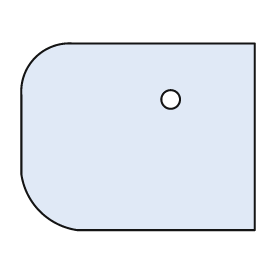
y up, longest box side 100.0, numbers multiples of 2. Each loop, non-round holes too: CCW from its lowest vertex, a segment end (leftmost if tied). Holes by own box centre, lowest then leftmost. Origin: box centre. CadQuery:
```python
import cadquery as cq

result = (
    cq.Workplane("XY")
    .moveTo(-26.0, -40.0)
    .lineTo(50.0, -40.0)
    .lineTo(50.0, 40.0)
    .lineTo(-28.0, 40.0)
    .threePointArc((-44.0, 34.0), (-50.0, 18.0))
    .lineTo(-50.0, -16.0)
    .threePointArc((-42.0, -32.0), (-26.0, -40.0))
    .close()
    .moveTo(14.0, 16.0)
    .circle(4.0)
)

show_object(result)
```